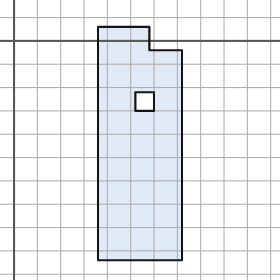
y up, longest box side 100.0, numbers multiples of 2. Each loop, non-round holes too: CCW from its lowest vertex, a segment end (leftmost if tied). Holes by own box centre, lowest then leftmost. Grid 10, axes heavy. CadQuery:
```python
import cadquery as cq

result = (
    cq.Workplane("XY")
    .moveTo(36.0, -94.0)
    .lineTo(72.0, -94.0)
    .lineTo(72.0, -4.0)
    .lineTo(58.0, -4.0)
    .lineTo(58.0, 6.0)
    .lineTo(36.0, 6.0)
    .close()
    .moveTo(52.0, -30.0)
    .lineTo(60.0, -30.0)
    .lineTo(60.0, -22.0)
    .lineTo(52.0, -22.0)
    .close()
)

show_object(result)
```